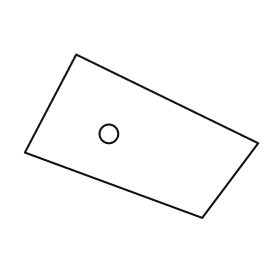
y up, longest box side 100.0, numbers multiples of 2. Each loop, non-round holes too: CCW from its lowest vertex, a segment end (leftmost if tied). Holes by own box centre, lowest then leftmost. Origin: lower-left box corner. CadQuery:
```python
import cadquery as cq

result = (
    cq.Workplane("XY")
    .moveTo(76.0, 0.0)
    .lineTo(100.0, 32.0)
    .lineTo(22.0, 70.0)
    .lineTo(0.0, 28.0)
    .close()
    .moveTo(36.0, 36.0)
    .circle(4.0)
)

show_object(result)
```